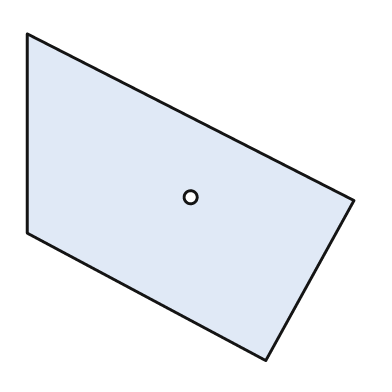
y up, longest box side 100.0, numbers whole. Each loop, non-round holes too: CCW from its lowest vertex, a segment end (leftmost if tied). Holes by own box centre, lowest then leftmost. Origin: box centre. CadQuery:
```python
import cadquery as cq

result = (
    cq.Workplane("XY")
    .moveTo(23.0, -50.0)
    .lineTo(50.0, -1.0)
    .lineTo(-50.0, 50.0)
    .lineTo(-50.0, -11.0)
    .close()
    .moveTo(0.0, 0.0)
    .circle(2.0)
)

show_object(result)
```